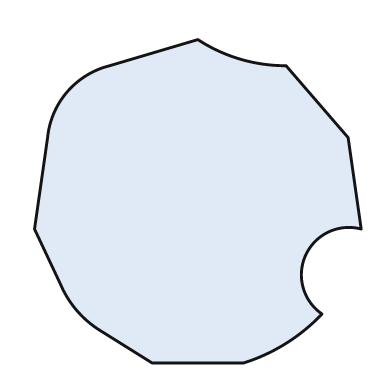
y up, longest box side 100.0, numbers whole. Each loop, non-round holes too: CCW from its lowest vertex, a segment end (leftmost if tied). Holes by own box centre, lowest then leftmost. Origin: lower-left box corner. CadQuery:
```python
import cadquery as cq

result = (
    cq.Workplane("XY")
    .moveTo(36.0, 0.0)
    .lineTo(64.0, 0.0)
    .threePointArc((77.0, 6.0), (88.0, 15.0))
    .threePointArc((83.0, 33.0), (100.0, 41.0))
    .lineTo(96.0, 69.0)
    .lineTo(77.0, 91.0)
    .threePointArc((63.0, 93.0), (50.0, 99.0))
    .lineTo(23.0, 91.0)
    .threePointArc((10.0, 83.0), (4.0, 69.0))
    .lineTo(0.0, 41.0)
    .lineTo(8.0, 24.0)
    .threePointArc((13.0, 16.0), (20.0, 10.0))
    .close()
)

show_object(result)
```